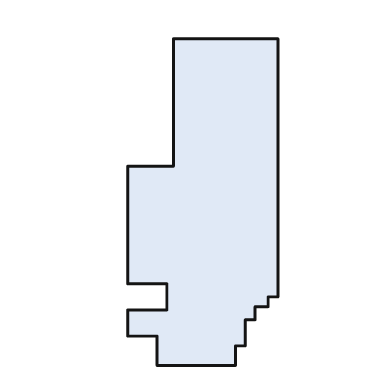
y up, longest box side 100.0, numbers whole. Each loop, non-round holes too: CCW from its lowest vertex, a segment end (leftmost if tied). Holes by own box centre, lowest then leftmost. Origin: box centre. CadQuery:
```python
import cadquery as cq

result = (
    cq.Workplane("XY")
    .moveTo(-14.0, -50.0)
    .lineTo(10.0, -50.0)
    .lineTo(10.0, -44.0)
    .lineTo(13.0, -44.0)
    .lineTo(13.0, -36.0)
    .lineTo(16.0, -36.0)
    .lineTo(16.0, -32.0)
    .lineTo(20.0, -32.0)
    .lineTo(20.0, -29.0)
    .lineTo(23.0, -29.0)
    .lineTo(23.0, 50.0)
    .lineTo(-9.0, 50.0)
    .lineTo(-9.0, 11.0)
    .lineTo(-23.0, 11.0)
    .lineTo(-23.0, -25.0)
    .lineTo(-11.0, -25.0)
    .lineTo(-11.0, -33.0)
    .lineTo(-23.0, -33.0)
    .lineTo(-23.0, -41.0)
    .lineTo(-14.0, -41.0)
    .close()
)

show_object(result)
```